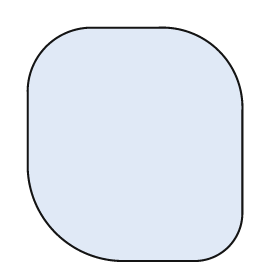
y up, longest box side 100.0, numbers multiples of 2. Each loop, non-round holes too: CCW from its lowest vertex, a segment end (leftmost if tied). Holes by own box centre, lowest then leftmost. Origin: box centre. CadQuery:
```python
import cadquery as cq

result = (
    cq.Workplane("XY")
    .moveTo(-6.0, -50.0)
    .lineTo(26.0, -50.0)
    .threePointArc((40.0, -44.0), (46.0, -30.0))
    .lineTo(46.0, 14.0)
    .threePointArc((36.0, 40.0), (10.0, 50.0))
    .lineTo(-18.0, 50.0)
    .threePointArc((-38.0, 42.0), (-46.0, 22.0))
    .lineTo(-46.0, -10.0)
    .threePointArc((-34.0, -38.0), (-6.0, -50.0))
    .close()
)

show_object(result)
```